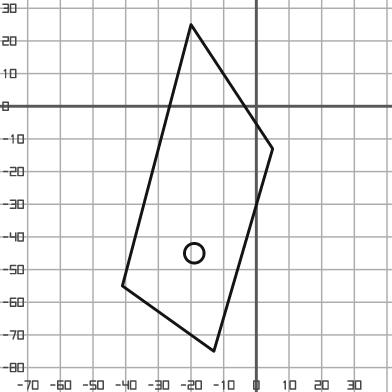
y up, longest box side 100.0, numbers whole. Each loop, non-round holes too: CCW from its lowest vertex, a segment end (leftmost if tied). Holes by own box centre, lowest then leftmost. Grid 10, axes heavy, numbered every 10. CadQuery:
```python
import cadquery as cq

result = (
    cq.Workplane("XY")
    .moveTo(-13.0, -75.0)
    .lineTo(5.0, -13.0)
    .lineTo(-20.0, 25.0)
    .lineTo(-41.0, -55.0)
    .close()
    .moveTo(-19.0, -45.0)
    .circle(3.0)
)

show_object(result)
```